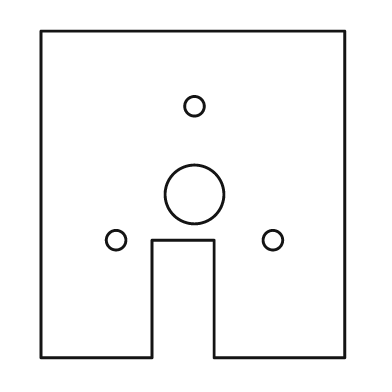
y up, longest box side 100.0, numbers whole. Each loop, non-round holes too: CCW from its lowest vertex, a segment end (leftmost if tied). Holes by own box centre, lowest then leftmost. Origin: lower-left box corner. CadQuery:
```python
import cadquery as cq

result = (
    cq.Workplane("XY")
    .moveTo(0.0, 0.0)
    .lineTo(34.0, 0.0)
    .lineTo(34.0, 36.0)
    .lineTo(53.0, 36.0)
    .lineTo(53.0, 0.0)
    .lineTo(93.0, 0.0)
    .lineTo(93.0, 100.0)
    .lineTo(0.0, 100.0)
    .close()
    .moveTo(23.0, 36.0)
    .circle(3.0)
    .moveTo(71.0, 36.0)
    .circle(3.0)
    .moveTo(47.0, 50.0)
    .circle(9.0)
    .moveTo(47.0, 77.0)
    .circle(3.0)
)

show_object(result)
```